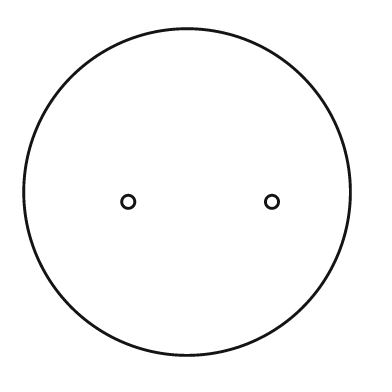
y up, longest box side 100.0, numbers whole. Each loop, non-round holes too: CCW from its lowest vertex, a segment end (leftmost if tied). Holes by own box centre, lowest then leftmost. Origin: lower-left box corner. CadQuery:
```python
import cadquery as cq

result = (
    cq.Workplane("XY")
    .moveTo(50.0, 50.0)
    .circle(50.0)
    .moveTo(32.0, 47.0)
    .circle(2.0)
    .moveTo(76.0, 47.0)
    .circle(2.0)
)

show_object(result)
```